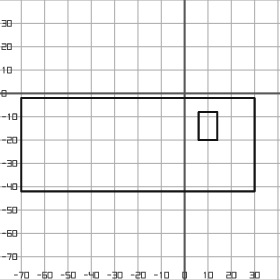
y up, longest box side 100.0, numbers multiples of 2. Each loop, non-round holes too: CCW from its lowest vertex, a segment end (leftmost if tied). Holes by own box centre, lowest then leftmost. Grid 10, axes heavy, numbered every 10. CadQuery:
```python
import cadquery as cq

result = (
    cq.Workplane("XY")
    .moveTo(-70.0, -42.0)
    .lineTo(30.0, -42.0)
    .lineTo(30.0, -2.0)
    .lineTo(-70.0, -2.0)
    .close()
    .moveTo(6.0, -20.0)
    .lineTo(14.0, -20.0)
    .lineTo(14.0, -8.0)
    .lineTo(6.0, -8.0)
    .close()
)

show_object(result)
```